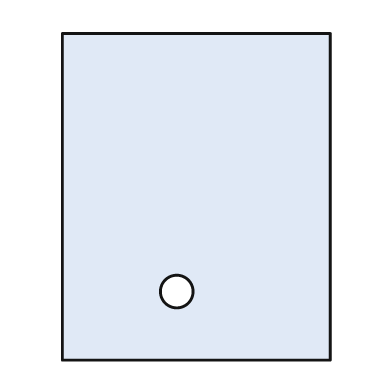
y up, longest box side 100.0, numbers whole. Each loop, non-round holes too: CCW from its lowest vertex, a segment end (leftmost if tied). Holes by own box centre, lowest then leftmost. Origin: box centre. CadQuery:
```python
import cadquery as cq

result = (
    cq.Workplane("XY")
    .moveTo(-41.0, -50.0)
    .lineTo(41.0, -50.0)
    .lineTo(41.0, 50.0)
    .lineTo(-41.0, 50.0)
    .close()
    .moveTo(-6.0, -29.0)
    .circle(5.0)
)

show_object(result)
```